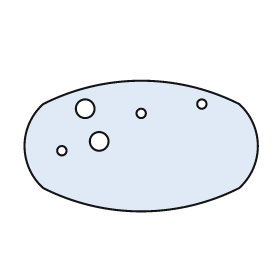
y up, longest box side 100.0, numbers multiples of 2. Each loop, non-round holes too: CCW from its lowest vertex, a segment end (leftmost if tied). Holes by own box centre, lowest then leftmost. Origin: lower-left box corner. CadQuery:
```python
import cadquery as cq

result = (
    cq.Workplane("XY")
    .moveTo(8.0, 10.0)
    .threePointArc((50.0, 0.0), (92.0, 10.0))
    .threePointArc((100.0, 28.0), (92.0, 46.0))
    .threePointArc((50.0, 56.0), (8.0, 46.0))
    .threePointArc((0.0, 28.0), (8.0, 10.0))
    .close()
    .moveTo(16.0, 26.0)
    .circle(2.0)
    .moveTo(32.0, 30.0)
    .circle(4.0)
    .moveTo(50.0, 42.0)
    .circle(2.0)
    .moveTo(26.0, 44.0)
    .circle(4.0)
    .moveTo(76.0, 46.0)
    .circle(2.0)
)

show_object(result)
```